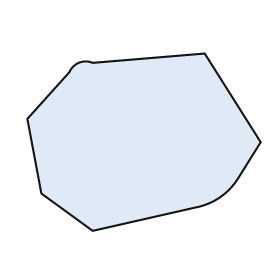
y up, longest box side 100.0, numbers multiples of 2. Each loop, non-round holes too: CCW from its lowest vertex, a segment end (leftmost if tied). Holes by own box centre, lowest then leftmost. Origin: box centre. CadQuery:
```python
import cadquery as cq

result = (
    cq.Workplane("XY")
    .moveTo(-22.0, -38.0)
    .lineTo(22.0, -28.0)
    .threePointArc((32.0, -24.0), (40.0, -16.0))
    .lineTo(50.0, 0.0)
    .lineTo(26.0, 38.0)
    .lineTo(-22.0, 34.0)
    .threePointArc((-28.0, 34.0), (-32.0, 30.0))
    .lineTo(-50.0, 10.0)
    .lineTo(-44.0, -22.0)
    .close()
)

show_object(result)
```